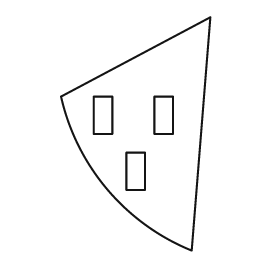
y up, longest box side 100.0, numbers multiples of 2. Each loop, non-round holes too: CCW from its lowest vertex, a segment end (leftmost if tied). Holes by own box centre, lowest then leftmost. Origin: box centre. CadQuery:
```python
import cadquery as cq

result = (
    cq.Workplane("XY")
    .moveTo(24.0, -50.0)
    .lineTo(32.0, 50.0)
    .lineTo(-32.0, 16.0)
    .threePointArc((-12.0, -24.0), (24.0, -50.0))
    .close()
    .moveTo(-4.0, -24.0)
    .lineTo(4.0, -24.0)
    .lineTo(4.0, -8.0)
    .lineTo(-4.0, -8.0)
    .close()
    .moveTo(-18.0, 0.0)
    .lineTo(-10.0, 0.0)
    .lineTo(-10.0, 16.0)
    .lineTo(-18.0, 16.0)
    .close()
    .moveTo(8.0, 0.0)
    .lineTo(16.0, 0.0)
    .lineTo(16.0, 16.0)
    .lineTo(8.0, 16.0)
    .close()
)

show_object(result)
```